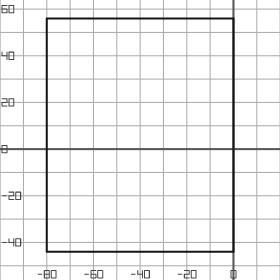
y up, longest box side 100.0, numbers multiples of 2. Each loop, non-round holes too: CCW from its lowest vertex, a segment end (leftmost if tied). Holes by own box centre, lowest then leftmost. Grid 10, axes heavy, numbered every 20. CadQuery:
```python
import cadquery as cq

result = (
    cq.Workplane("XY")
    .moveTo(-80.0, -44.0)
    .lineTo(0.0, -44.0)
    .lineTo(0.0, 56.0)
    .lineTo(-80.0, 56.0)
    .close()
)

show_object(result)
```